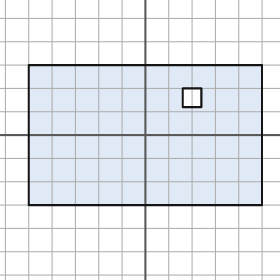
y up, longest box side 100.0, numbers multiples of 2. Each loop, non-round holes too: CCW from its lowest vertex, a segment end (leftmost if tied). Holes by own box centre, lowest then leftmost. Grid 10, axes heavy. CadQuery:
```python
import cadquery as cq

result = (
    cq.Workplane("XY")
    .moveTo(-50.0, -30.0)
    .lineTo(50.0, -30.0)
    .lineTo(50.0, 30.0)
    .lineTo(-50.0, 30.0)
    .close()
    .moveTo(16.0, 12.0)
    .lineTo(24.0, 12.0)
    .lineTo(24.0, 20.0)
    .lineTo(16.0, 20.0)
    .close()
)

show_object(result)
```